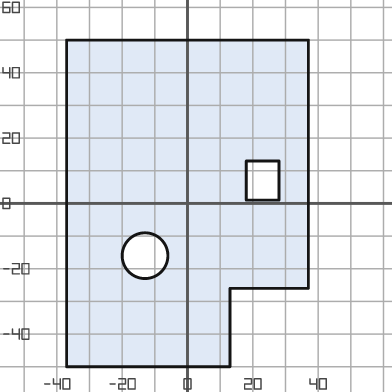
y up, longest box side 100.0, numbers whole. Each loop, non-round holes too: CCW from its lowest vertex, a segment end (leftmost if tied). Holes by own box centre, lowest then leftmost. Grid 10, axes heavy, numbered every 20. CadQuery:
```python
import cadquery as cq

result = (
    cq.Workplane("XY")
    .moveTo(-37.0, -50.0)
    .lineTo(13.0, -50.0)
    .lineTo(13.0, -26.0)
    .lineTo(37.0, -26.0)
    .lineTo(37.0, 50.0)
    .lineTo(-37.0, 50.0)
    .close()
    .moveTo(-13.0, -16.0)
    .circle(7.0)
    .moveTo(18.0, 1.0)
    .lineTo(28.0, 1.0)
    .lineTo(28.0, 13.0)
    .lineTo(18.0, 13.0)
    .close()
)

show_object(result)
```